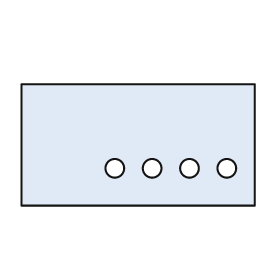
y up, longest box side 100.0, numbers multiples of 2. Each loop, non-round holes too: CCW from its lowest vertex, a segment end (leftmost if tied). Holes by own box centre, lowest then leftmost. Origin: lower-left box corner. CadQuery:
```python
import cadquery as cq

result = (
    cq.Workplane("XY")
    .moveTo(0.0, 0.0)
    .lineTo(100.0, 0.0)
    .lineTo(100.0, 52.0)
    .lineTo(0.0, 52.0)
    .close()
    .moveTo(40.0, 16.0)
    .circle(4.0)
    .moveTo(56.0, 16.0)
    .circle(4.0)
    .moveTo(72.0, 16.0)
    .circle(4.0)
    .moveTo(88.0, 16.0)
    .circle(4.0)
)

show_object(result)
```